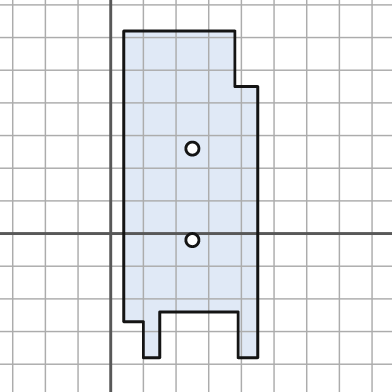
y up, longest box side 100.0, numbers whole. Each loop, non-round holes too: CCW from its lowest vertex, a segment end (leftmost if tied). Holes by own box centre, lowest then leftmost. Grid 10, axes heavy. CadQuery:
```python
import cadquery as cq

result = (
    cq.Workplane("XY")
    .moveTo(10.0, -38.0)
    .lineTo(15.0, -38.0)
    .lineTo(15.0, -24.0)
    .lineTo(39.0, -24.0)
    .lineTo(39.0, -38.0)
    .lineTo(45.0, -38.0)
    .lineTo(45.0, 45.0)
    .lineTo(38.0, 45.0)
    .lineTo(38.0, 62.0)
    .lineTo(4.0, 62.0)
    .lineTo(4.0, -27.0)
    .lineTo(10.0, -27.0)
    .close()
    .moveTo(25.0, -2.0)
    .circle(2.0)
    .moveTo(25.0, 26.0)
    .circle(2.0)
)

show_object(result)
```